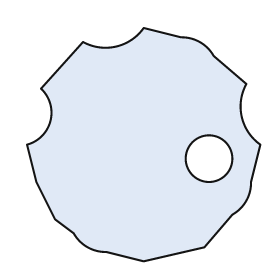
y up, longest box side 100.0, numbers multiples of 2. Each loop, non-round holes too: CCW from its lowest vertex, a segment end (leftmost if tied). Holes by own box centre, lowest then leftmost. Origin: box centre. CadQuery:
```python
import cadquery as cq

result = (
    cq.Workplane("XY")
    .moveTo(0.0, -50.0)
    .lineTo(26.0, -44.0)
    .lineTo(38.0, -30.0)
    .threePointArc((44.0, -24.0), (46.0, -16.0))
    .lineTo(50.0, 0.0)
    .threePointArc((42.0, 12.0), (44.0, 26.0))
    .lineTo(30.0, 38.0)
    .threePointArc((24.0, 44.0), (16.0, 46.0))
    .lineTo(0.0, 50.0)
    .threePointArc((-12.0, 42.0), (-26.0, 44.0))
    .lineTo(-44.0, 24.0)
    .threePointArc((-40.0, 10.0), (-50.0, 0.0))
    .lineTo(-46.0, -16.0)
    .lineTo(-38.0, -32.0)
    .lineTo(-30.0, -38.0)
    .threePointArc((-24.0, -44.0), (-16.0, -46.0))
    .close()
    .moveTo(28.0, -6.0)
    .circle(10.0)
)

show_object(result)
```